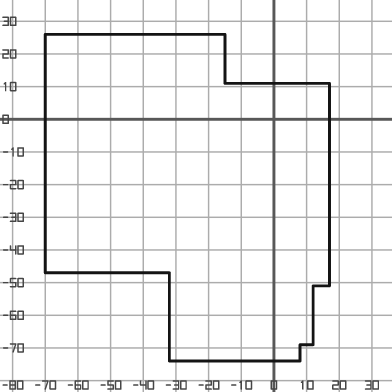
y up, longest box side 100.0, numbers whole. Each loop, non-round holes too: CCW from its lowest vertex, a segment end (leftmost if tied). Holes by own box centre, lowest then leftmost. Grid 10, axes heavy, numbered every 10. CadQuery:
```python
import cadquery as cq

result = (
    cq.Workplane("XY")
    .moveTo(-32.0, -74.0)
    .lineTo(8.0, -74.0)
    .lineTo(8.0, -69.0)
    .lineTo(12.0, -69.0)
    .lineTo(12.0, -51.0)
    .lineTo(17.0, -51.0)
    .lineTo(17.0, 11.0)
    .lineTo(-15.0, 11.0)
    .lineTo(-15.0, 26.0)
    .lineTo(-70.0, 26.0)
    .lineTo(-70.0, -47.0)
    .lineTo(-32.0, -47.0)
    .close()
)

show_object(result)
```